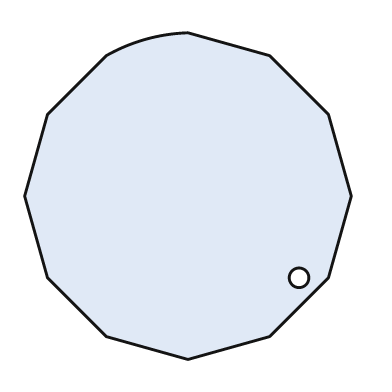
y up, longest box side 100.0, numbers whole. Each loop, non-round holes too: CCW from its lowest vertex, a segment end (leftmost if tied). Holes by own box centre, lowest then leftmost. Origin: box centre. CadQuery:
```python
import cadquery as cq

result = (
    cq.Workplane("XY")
    .moveTo(0.0, -50.0)
    .lineTo(25.0, -43.0)
    .lineTo(43.0, -25.0)
    .lineTo(50.0, 0.0)
    .lineTo(43.0, 25.0)
    .lineTo(25.0, 43.0)
    .lineTo(0.0, 50.0)
    .threePointArc((-13.0, 48.0), (-25.0, 43.0))
    .lineTo(-43.0, 25.0)
    .lineTo(-50.0, 0.0)
    .lineTo(-43.0, -25.0)
    .lineTo(-25.0, -43.0)
    .close()
    .moveTo(34.0, -25.0)
    .circle(3.0)
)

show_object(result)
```